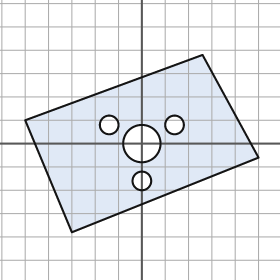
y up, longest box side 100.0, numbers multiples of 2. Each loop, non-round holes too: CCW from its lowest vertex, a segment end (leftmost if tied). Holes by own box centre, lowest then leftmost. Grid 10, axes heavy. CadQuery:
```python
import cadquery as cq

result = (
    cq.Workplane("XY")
    .moveTo(-30.0, -38.0)
    .lineTo(50.0, -6.0)
    .lineTo(26.0, 38.0)
    .lineTo(-50.0, 10.0)
    .close()
    .moveTo(0.0, -16.0)
    .circle(4.0)
    .moveTo(0.0, 0.0)
    .circle(8.0)
    .moveTo(-14.0, 8.0)
    .circle(4.0)
    .moveTo(14.0, 8.0)
    .circle(4.0)
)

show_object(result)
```